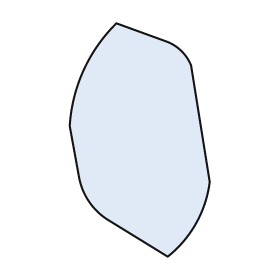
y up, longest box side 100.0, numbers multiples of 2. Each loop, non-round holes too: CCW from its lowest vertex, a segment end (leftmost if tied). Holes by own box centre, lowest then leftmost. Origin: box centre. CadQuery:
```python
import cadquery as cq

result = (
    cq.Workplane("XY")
    .moveTo(12.0, -50.0)
    .threePointArc((24.0, -36.0), (30.0, -18.0))
    .lineTo(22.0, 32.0)
    .threePointArc((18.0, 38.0), (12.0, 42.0))
    .lineTo(-10.0, 50.0)
    .threePointArc((-24.0, 30.0), (-30.0, 6.0))
    .lineTo(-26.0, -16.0)
    .threePointArc((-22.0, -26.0), (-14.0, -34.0))
    .close()
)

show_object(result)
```